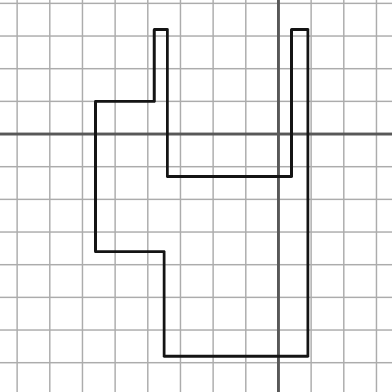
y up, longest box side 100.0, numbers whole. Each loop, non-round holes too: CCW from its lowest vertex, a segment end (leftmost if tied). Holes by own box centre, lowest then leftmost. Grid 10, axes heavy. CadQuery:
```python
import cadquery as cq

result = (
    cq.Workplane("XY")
    .moveTo(-35.0, -68.0)
    .lineTo(9.0, -68.0)
    .lineTo(9.0, 32.0)
    .lineTo(4.0, 32.0)
    .lineTo(4.0, -13.0)
    .lineTo(-34.0, -13.0)
    .lineTo(-34.0, 32.0)
    .lineTo(-38.0, 32.0)
    .lineTo(-38.0, 10.0)
    .lineTo(-56.0, 10.0)
    .lineTo(-56.0, -36.0)
    .lineTo(-35.0, -36.0)
    .close()
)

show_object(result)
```